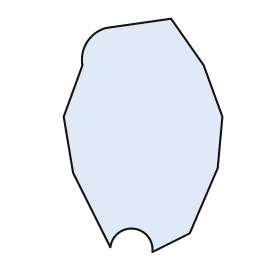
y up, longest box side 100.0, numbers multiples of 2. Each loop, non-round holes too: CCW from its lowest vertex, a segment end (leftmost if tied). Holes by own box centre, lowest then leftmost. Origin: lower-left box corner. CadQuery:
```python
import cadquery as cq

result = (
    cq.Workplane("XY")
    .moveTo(38.0, 0.0)
    .lineTo(54.0, 8.0)
    .lineTo(66.0, 36.0)
    .lineTo(68.0, 58.0)
    .lineTo(60.0, 80.0)
    .lineTo(46.0, 100.0)
    .lineTo(18.0, 96.0)
    .threePointArc((10.0, 90.0), (8.0, 80.0))
    .lineTo(0.0, 58.0)
    .lineTo(4.0, 34.0)
    .lineTo(20.0, 2.0)
    .threePointArc((30.0, 10.0), (38.0, 0.0))
    .close()
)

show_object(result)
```